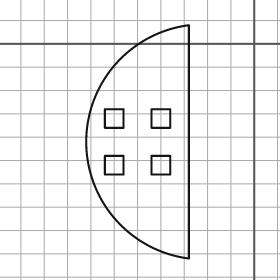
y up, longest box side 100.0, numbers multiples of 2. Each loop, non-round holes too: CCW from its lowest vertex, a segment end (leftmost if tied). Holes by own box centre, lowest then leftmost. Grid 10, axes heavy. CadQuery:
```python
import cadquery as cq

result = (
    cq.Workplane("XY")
    .moveTo(-28.0, -92.0)
    .lineTo(-28.0, 8.0)
    .threePointArc((-72.0, -42.0), (-28.0, -92.0))
    .close()
    .moveTo(-64.0, -56.0)
    .lineTo(-56.0, -56.0)
    .lineTo(-56.0, -48.0)
    .lineTo(-64.0, -48.0)
    .close()
    .moveTo(-44.0, -56.0)
    .lineTo(-36.0, -56.0)
    .lineTo(-36.0, -48.0)
    .lineTo(-44.0, -48.0)
    .close()
    .moveTo(-64.0, -36.0)
    .lineTo(-56.0, -36.0)
    .lineTo(-56.0, -28.0)
    .lineTo(-64.0, -28.0)
    .close()
    .moveTo(-44.0, -36.0)
    .lineTo(-36.0, -36.0)
    .lineTo(-36.0, -28.0)
    .lineTo(-44.0, -28.0)
    .close()
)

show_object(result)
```